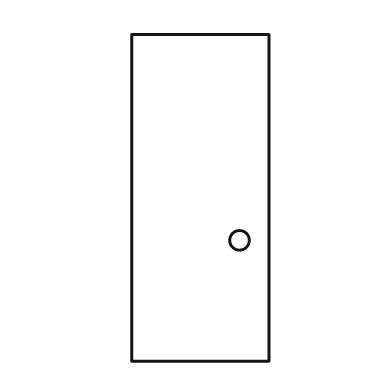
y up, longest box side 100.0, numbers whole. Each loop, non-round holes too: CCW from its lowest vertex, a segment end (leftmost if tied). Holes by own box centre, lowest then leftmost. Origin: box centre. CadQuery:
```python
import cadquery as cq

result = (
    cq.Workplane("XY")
    .moveTo(-21.0, -50.0)
    .lineTo(21.0, -50.0)
    .lineTo(21.0, 50.0)
    .lineTo(-21.0, 50.0)
    .close()
    .moveTo(12.0, -13.0)
    .circle(3.0)
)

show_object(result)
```